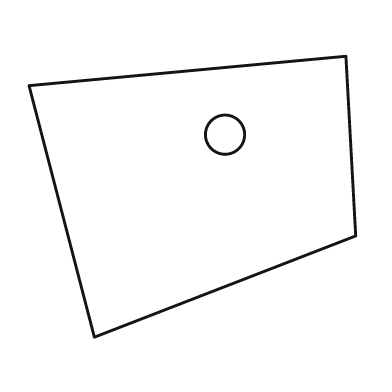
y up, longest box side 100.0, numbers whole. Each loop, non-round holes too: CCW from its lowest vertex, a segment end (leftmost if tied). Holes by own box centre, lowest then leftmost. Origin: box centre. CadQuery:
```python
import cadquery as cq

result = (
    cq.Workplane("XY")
    .moveTo(-30.0, -43.0)
    .lineTo(50.0, -12.0)
    .lineTo(47.0, 43.0)
    .lineTo(-50.0, 34.0)
    .close()
    .moveTo(10.0, 19.0)
    .circle(6.0)
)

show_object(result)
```